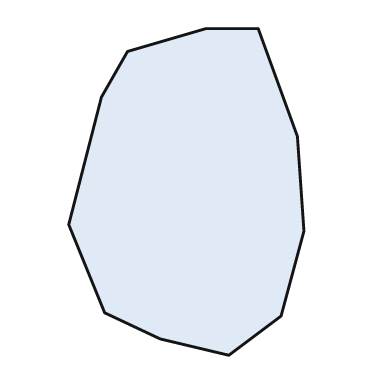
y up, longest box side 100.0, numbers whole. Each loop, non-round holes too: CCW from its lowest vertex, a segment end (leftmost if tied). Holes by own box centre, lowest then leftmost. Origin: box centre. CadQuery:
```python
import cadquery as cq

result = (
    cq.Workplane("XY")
    .moveTo(13.0, -50.0)
    .lineTo(29.0, -38.0)
    .lineTo(36.0, -12.0)
    .lineTo(34.0, 17.0)
    .lineTo(22.0, 50.0)
    .lineTo(6.0, 50.0)
    .lineTo(-18.0, 43.0)
    .lineTo(-26.0, 29.0)
    .lineTo(-36.0, -10.0)
    .lineTo(-25.0, -37.0)
    .lineTo(-8.0, -45.0)
    .close()
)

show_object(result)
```